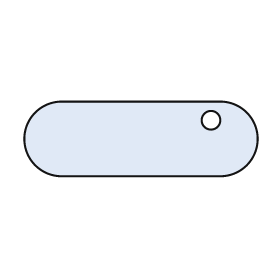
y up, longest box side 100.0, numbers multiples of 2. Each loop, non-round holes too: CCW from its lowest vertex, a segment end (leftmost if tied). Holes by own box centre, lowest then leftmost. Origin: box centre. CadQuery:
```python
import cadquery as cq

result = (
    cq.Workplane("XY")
    .moveTo(-34.0, -16.0)
    .lineTo(34.0, -16.0)
    .threePointArc((50.0, 0.0), (34.0, 16.0))
    .lineTo(-34.0, 16.0)
    .threePointArc((-50.0, 0.0), (-34.0, -16.0))
    .close()
    .moveTo(30.0, 8.0)
    .circle(4.0)
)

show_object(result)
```